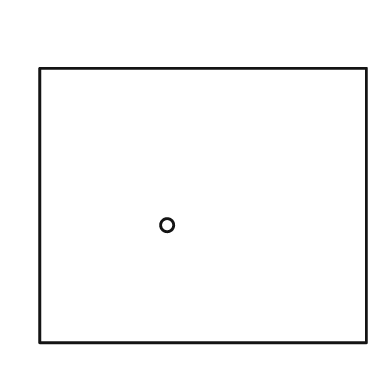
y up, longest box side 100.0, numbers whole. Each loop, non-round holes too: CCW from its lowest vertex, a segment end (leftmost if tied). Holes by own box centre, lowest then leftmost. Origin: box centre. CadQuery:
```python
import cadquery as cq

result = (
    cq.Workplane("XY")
    .moveTo(-50.0, -42.0)
    .lineTo(50.0, -42.0)
    .lineTo(50.0, 42.0)
    .lineTo(-50.0, 42.0)
    .close()
    .moveTo(-11.0, -6.0)
    .circle(2.0)
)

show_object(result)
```